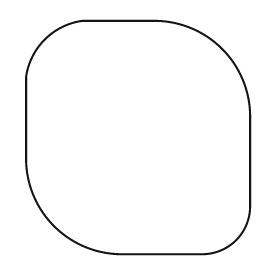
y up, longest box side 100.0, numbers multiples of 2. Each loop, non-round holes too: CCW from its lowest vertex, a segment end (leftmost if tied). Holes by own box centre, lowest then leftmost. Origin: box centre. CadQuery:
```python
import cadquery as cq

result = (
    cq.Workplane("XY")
    .moveTo(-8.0, -50.0)
    .lineTo(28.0, -50.0)
    .threePointArc((42.0, -44.0), (48.0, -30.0))
    .lineTo(48.0, 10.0)
    .threePointArc((36.0, 38.0), (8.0, 50.0))
    .lineTo(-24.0, 50.0)
    .threePointArc((-40.0, 42.0), (-48.0, 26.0))
    .lineTo(-48.0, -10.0)
    .threePointArc((-36.0, -38.0), (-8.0, -50.0))
    .close()
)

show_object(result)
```